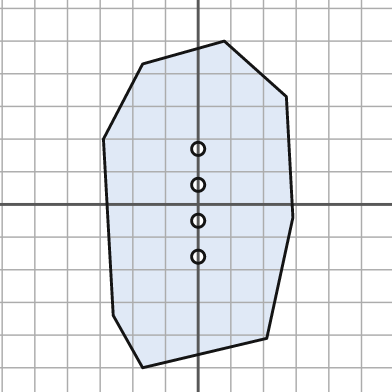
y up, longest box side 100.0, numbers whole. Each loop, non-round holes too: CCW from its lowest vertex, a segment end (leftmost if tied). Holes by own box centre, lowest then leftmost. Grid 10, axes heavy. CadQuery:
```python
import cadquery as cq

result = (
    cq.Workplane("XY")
    .moveTo(-17.0, -50.0)
    .lineTo(21.0, -41.0)
    .lineTo(29.0, -4.0)
    .lineTo(27.0, 33.0)
    .lineTo(8.0, 50.0)
    .lineTo(-17.0, 43.0)
    .lineTo(-29.0, 20.0)
    .lineTo(-26.0, -34.0)
    .close()
    .moveTo(0.0, -16.0)
    .circle(2.0)
    .moveTo(0.0, -5.0)
    .circle(2.0)
    .moveTo(0.0, 6.0)
    .circle(2.0)
    .moveTo(0.0, 17.0)
    .circle(2.0)
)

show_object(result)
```